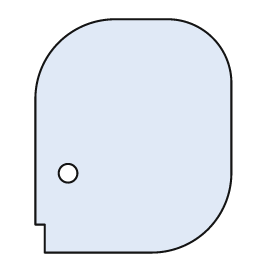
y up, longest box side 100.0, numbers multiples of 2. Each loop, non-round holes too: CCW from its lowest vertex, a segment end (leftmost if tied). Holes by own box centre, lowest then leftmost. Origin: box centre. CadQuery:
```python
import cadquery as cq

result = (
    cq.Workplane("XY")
    .moveTo(-38.0, -50.0)
    .lineTo(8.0, -50.0)
    .threePointArc((32.0, -40.0), (42.0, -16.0))
    .lineTo(42.0, 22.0)
    .threePointArc((34.0, 42.0), (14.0, 50.0))
    .lineTo(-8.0, 50.0)
    .threePointArc((-32.0, 40.0), (-42.0, 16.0))
    .lineTo(-42.0, -38.0)
    .lineTo(-38.0, -38.0)
    .close()
    .moveTo(-28.0, -16.0)
    .circle(4.0)
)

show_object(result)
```